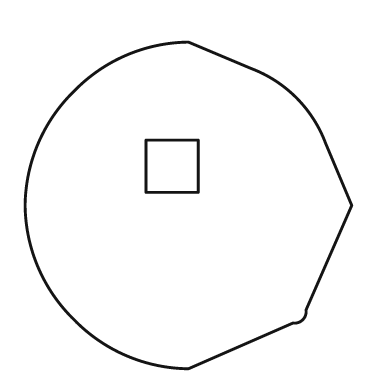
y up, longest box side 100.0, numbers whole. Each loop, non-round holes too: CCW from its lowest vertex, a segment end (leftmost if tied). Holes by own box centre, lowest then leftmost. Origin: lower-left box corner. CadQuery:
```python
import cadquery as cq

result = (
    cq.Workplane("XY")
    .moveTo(50.0, 0.0)
    .lineTo(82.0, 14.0)
    .threePointArc((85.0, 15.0), (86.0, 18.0))
    .lineTo(100.0, 50.0)
    .lineTo(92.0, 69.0)
    .threePointArc((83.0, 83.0), (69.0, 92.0))
    .lineTo(50.0, 100.0)
    .threePointArc((31.0, 96.0), (15.0, 85.0))
    .threePointArc((4.0, 69.0), (0.0, 50.0))
    .threePointArc((4.0, 31.0), (15.0, 15.0))
    .threePointArc((31.0, 4.0), (50.0, 0.0))
    .close()
    .moveTo(37.0, 54.0)
    .lineTo(53.0, 54.0)
    .lineTo(53.0, 70.0)
    .lineTo(37.0, 70.0)
    .close()
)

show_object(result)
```